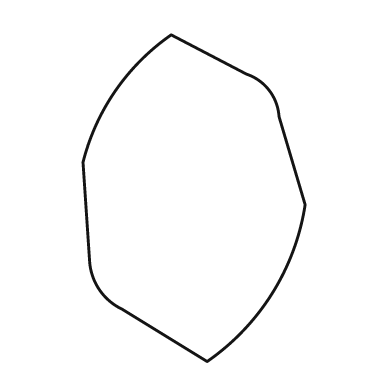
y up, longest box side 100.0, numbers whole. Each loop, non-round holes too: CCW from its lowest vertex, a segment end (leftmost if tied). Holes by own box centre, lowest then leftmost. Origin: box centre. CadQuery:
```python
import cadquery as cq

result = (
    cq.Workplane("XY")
    .moveTo(4.0, -50.0)
    .threePointArc((24.0, -29.0), (34.0, -2.0))
    .lineTo(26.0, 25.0)
    .threePointArc((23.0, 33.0), (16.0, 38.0))
    .lineTo(-7.0, 50.0)
    .threePointArc((-24.0, 33.0), (-34.0, 11.0))
    .lineTo(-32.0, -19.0)
    .threePointArc((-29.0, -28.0), (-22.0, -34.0))
    .close()
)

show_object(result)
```